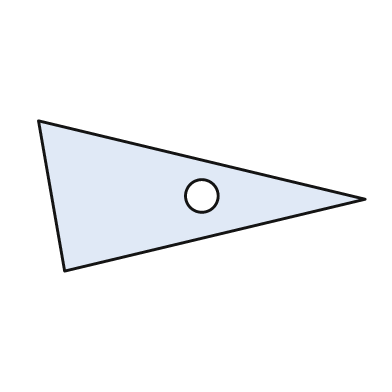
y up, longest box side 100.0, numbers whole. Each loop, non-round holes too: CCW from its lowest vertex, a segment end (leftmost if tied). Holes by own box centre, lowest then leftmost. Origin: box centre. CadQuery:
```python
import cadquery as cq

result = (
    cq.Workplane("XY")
    .moveTo(-42.0, -23.0)
    .lineTo(50.0, -1.0)
    .lineTo(-50.0, 23.0)
    .close()
    .moveTo(0.0, 0.0)
    .circle(5.0)
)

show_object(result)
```